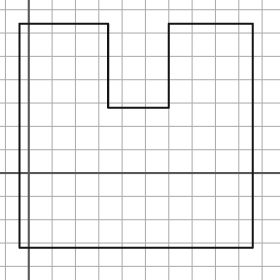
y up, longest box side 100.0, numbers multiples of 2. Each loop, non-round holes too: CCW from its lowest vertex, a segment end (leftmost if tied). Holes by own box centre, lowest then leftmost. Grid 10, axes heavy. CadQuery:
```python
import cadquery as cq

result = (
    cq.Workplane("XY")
    .moveTo(-4.0, -32.0)
    .lineTo(96.0, -32.0)
    .lineTo(96.0, 64.0)
    .lineTo(60.0, 64.0)
    .lineTo(60.0, 28.0)
    .lineTo(34.0, 28.0)
    .lineTo(34.0, 64.0)
    .lineTo(-4.0, 64.0)
    .close()
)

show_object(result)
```